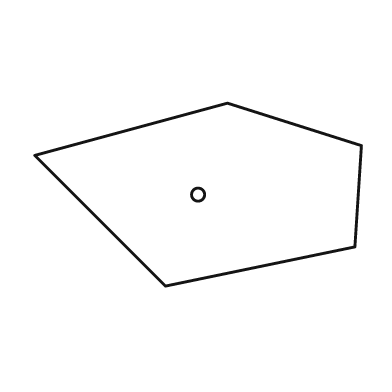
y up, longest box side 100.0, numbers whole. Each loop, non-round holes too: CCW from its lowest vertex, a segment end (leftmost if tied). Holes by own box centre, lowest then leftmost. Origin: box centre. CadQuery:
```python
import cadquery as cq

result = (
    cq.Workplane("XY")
    .moveTo(-10.0, -28.0)
    .lineTo(48.0, -16.0)
    .lineTo(50.0, 15.0)
    .lineTo(9.0, 28.0)
    .lineTo(-50.0, 12.0)
    .close()
    .moveTo(0.0, 0.0)
    .circle(2.0)
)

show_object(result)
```